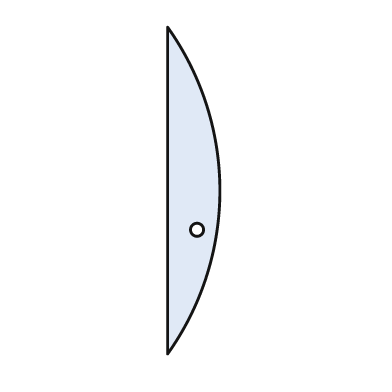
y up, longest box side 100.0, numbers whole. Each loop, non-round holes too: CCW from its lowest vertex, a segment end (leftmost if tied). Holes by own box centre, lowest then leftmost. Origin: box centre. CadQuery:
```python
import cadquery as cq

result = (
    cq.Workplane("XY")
    .moveTo(-8.0, -50.0)
    .threePointArc((8.0, 0.0), (-8.0, 50.0))
    .close()
    .moveTo(1.0, -12.0)
    .circle(2.0)
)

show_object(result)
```